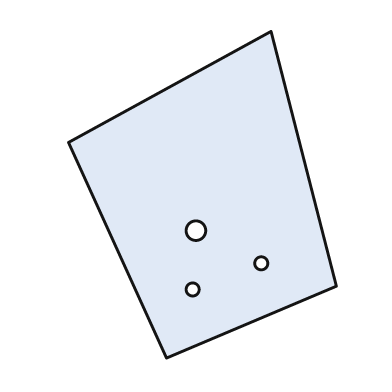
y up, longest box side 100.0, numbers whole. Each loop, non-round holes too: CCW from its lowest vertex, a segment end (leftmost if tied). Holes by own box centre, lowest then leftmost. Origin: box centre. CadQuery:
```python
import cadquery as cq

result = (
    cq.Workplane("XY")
    .moveTo(-11.0, -50.0)
    .lineTo(41.0, -28.0)
    .lineTo(21.0, 50.0)
    .lineTo(-41.0, 16.0)
    .close()
    .moveTo(-3.0, -29.0)
    .circle(2.0)
    .moveTo(18.0, -21.0)
    .circle(2.0)
    .moveTo(-2.0, -11.0)
    .circle(3.0)
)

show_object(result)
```